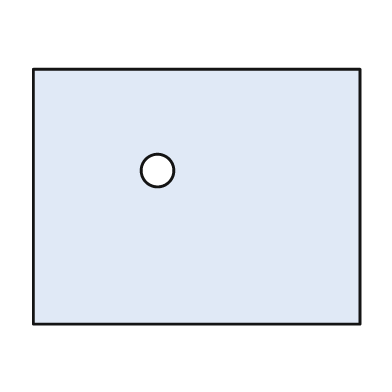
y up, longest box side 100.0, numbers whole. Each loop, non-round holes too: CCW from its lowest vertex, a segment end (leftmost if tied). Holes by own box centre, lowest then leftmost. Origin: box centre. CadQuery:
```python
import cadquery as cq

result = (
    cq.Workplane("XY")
    .moveTo(-50.0, -39.0)
    .lineTo(50.0, -39.0)
    .lineTo(50.0, 39.0)
    .lineTo(-50.0, 39.0)
    .close()
    .moveTo(-12.0, 8.0)
    .circle(5.0)
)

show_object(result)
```